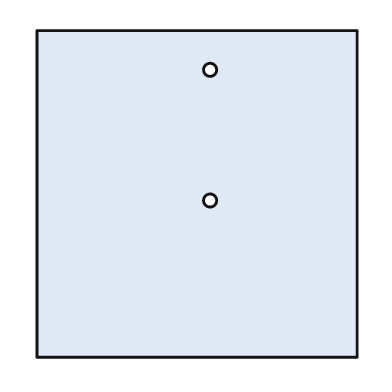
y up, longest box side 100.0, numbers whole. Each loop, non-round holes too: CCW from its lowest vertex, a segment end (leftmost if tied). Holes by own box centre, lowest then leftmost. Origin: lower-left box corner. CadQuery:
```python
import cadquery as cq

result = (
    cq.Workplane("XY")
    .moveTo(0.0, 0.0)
    .lineTo(98.0, 0.0)
    .lineTo(98.0, 100.0)
    .lineTo(0.0, 100.0)
    .close()
    .moveTo(53.0, 48.0)
    .circle(2.0)
    .moveTo(53.0, 88.0)
    .circle(2.0)
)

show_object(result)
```